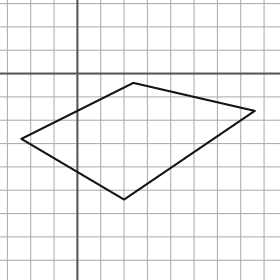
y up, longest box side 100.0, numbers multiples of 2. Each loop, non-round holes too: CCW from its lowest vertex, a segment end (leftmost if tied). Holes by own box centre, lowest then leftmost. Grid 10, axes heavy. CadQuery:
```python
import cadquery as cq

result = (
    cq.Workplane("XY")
    .moveTo(20.0, -54.0)
    .lineTo(76.0, -16.0)
    .lineTo(24.0, -4.0)
    .lineTo(-24.0, -28.0)
    .close()
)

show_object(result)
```